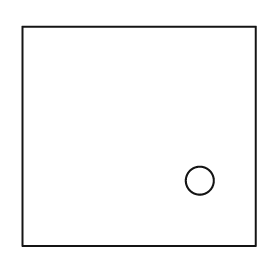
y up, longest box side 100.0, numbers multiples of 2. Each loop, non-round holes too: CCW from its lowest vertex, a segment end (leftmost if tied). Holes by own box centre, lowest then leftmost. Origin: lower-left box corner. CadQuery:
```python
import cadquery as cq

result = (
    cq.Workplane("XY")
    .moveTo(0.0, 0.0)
    .lineTo(100.0, 0.0)
    .lineTo(100.0, 94.0)
    .lineTo(0.0, 94.0)
    .close()
    .moveTo(76.0, 28.0)
    .circle(6.0)
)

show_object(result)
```